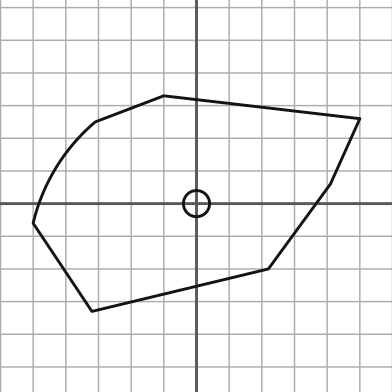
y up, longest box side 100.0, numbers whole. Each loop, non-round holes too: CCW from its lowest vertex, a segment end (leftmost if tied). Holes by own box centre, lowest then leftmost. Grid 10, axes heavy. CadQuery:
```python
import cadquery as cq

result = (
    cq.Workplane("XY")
    .moveTo(-32.0, -33.0)
    .lineTo(22.0, -20.0)
    .lineTo(41.0, 6.0)
    .lineTo(50.0, 26.0)
    .lineTo(-10.0, 33.0)
    .lineTo(-31.0, 25.0)
    .threePointArc((-43.0, 11.0), (-50.0, -6.0))
    .close()
    .moveTo(0.0, 0.0)
    .circle(4.0)
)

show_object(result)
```